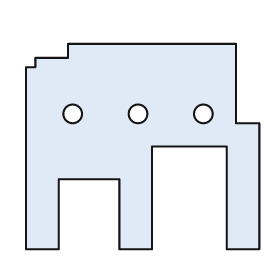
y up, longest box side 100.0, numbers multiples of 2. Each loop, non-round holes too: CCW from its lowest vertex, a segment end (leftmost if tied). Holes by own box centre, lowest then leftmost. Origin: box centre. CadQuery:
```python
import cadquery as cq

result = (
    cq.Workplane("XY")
    .moveTo(-50.0, -44.0)
    .lineTo(-36.0, -44.0)
    .lineTo(-36.0, -14.0)
    .lineTo(-10.0, -14.0)
    .lineTo(-10.0, -44.0)
    .lineTo(4.0, -44.0)
    .lineTo(4.0, 0.0)
    .lineTo(36.0, 0.0)
    .lineTo(36.0, -44.0)
    .lineTo(50.0, -44.0)
    .lineTo(50.0, 10.0)
    .lineTo(40.0, 10.0)
    .lineTo(40.0, 44.0)
    .lineTo(-32.0, 44.0)
    .lineTo(-32.0, 38.0)
    .lineTo(-46.0, 38.0)
    .lineTo(-46.0, 34.0)
    .lineTo(-50.0, 34.0)
    .close()
    .moveTo(-30.0, 14.0)
    .circle(4.0)
    .moveTo(-2.0, 14.0)
    .circle(4.0)
    .moveTo(26.0, 14.0)
    .circle(4.0)
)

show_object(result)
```